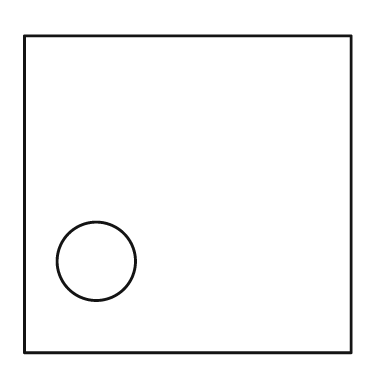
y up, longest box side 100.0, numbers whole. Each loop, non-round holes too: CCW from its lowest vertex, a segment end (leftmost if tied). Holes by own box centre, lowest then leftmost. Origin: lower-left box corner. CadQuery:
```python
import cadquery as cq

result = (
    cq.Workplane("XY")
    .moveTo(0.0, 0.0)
    .lineTo(100.0, 0.0)
    .lineTo(100.0, 97.0)
    .lineTo(0.0, 97.0)
    .close()
    .moveTo(22.0, 28.0)
    .circle(12.0)
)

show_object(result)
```